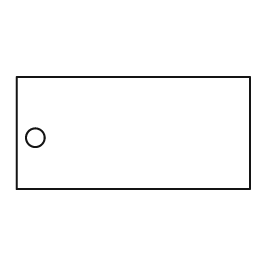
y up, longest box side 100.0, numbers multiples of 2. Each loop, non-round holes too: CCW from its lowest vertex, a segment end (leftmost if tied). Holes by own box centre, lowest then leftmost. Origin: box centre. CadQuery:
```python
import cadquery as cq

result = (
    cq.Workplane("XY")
    .moveTo(-50.0, -24.0)
    .lineTo(50.0, -24.0)
    .lineTo(50.0, 24.0)
    .lineTo(-50.0, 24.0)
    .close()
    .moveTo(-42.0, -2.0)
    .circle(4.0)
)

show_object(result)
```